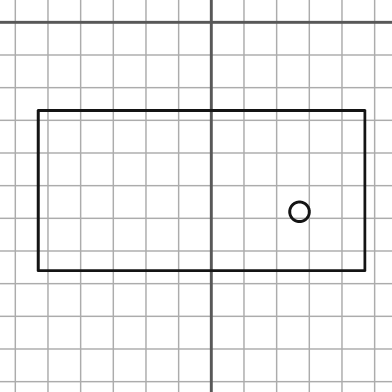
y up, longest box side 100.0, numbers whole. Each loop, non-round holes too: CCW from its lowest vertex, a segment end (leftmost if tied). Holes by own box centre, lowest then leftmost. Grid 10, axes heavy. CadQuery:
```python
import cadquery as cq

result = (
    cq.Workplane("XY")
    .moveTo(-53.0, -76.0)
    .lineTo(47.0, -76.0)
    .lineTo(47.0, -27.0)
    .lineTo(-53.0, -27.0)
    .close()
    .moveTo(27.0, -58.0)
    .circle(3.0)
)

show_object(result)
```